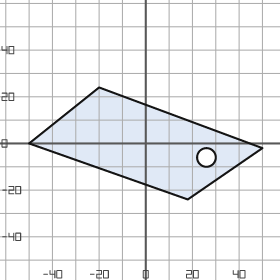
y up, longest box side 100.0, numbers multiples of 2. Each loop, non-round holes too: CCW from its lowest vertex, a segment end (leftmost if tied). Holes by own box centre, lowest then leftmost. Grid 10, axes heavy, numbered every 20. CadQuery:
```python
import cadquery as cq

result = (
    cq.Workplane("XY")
    .moveTo(18.0, -24.0)
    .lineTo(50.0, -2.0)
    .lineTo(-20.0, 24.0)
    .lineTo(-50.0, 0.0)
    .close()
    .moveTo(26.0, -6.0)
    .circle(4.0)
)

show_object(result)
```